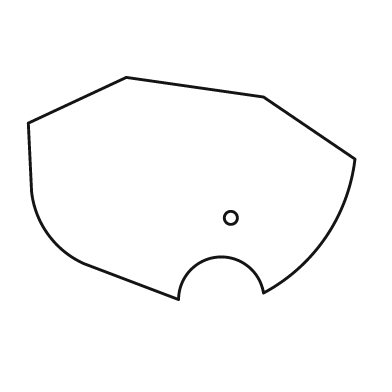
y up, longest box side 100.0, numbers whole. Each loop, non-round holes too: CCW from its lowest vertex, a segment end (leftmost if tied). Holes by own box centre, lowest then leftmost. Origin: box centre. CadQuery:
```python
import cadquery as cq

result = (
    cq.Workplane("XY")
    .moveTo(-4.0, -34.0)
    .threePointArc((8.0, -21.0), (22.0, -32.0))
    .threePointArc((41.0, -15.0), (50.0, 9.0))
    .lineTo(22.0, 28.0)
    .lineTo(-20.0, 34.0)
    .lineTo(-50.0, 20.0)
    .lineTo(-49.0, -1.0)
    .threePointArc((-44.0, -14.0), (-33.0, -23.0))
    .close()
    .moveTo(12.0, -9.0)
    .circle(2.0)
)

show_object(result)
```